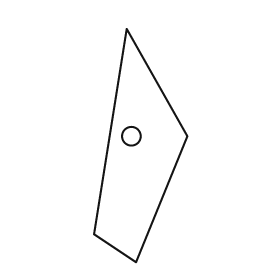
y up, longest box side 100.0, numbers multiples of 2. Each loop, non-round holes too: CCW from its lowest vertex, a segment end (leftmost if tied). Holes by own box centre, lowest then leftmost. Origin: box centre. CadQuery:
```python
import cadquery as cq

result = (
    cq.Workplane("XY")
    .moveTo(-2.0, -50.0)
    .lineTo(20.0, 4.0)
    .lineTo(-6.0, 50.0)
    .lineTo(-20.0, -38.0)
    .close()
    .moveTo(-4.0, 4.0)
    .circle(4.0)
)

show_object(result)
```